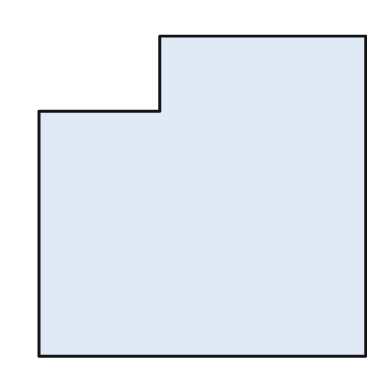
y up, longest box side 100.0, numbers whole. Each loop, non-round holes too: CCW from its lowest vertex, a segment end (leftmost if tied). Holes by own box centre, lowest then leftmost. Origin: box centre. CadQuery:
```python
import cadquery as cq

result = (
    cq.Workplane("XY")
    .moveTo(-50.0, -49.0)
    .lineTo(50.0, -49.0)
    .lineTo(50.0, 49.0)
    .lineTo(-13.0, 49.0)
    .lineTo(-13.0, 26.0)
    .lineTo(-50.0, 26.0)
    .close()
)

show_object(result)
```